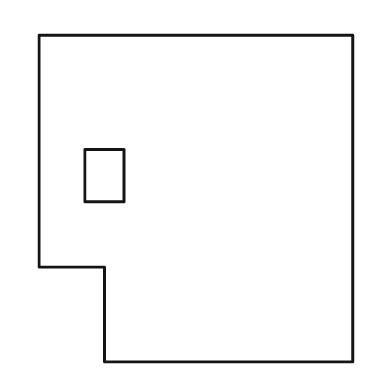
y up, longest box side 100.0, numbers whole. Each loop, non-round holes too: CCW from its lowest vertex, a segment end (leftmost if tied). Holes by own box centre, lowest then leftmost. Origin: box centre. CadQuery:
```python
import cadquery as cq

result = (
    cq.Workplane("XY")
    .moveTo(-28.0, -50.0)
    .lineTo(48.0, -50.0)
    .lineTo(48.0, 50.0)
    .lineTo(-48.0, 50.0)
    .lineTo(-48.0, -21.0)
    .lineTo(-28.0, -21.0)
    .close()
    .moveTo(-34.0, -1.0)
    .lineTo(-22.0, -1.0)
    .lineTo(-22.0, 15.0)
    .lineTo(-34.0, 15.0)
    .close()
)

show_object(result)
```